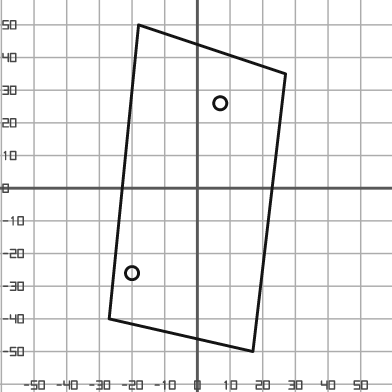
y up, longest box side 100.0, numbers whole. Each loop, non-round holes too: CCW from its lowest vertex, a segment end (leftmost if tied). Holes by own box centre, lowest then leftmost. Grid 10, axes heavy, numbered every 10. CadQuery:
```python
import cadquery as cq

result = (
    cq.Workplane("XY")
    .moveTo(17.0, -50.0)
    .lineTo(27.0, 35.0)
    .lineTo(-18.0, 50.0)
    .lineTo(-27.0, -40.0)
    .close()
    .moveTo(-20.0, -26.0)
    .circle(2.0)
    .moveTo(7.0, 26.0)
    .circle(2.0)
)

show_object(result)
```